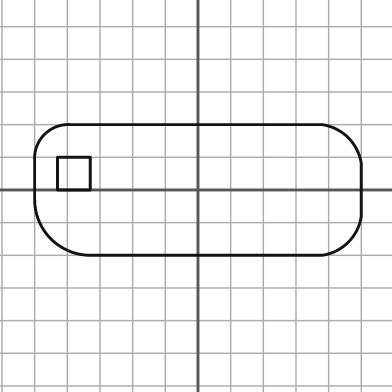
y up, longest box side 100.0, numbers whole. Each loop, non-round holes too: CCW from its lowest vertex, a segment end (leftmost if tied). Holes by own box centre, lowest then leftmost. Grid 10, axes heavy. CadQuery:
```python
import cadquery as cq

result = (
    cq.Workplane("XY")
    .moveTo(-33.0, -20.0)
    .lineTo(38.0, -20.0)
    .threePointArc((46.0, -16.0), (50.0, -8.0))
    .lineTo(50.0, 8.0)
    .threePointArc((46.0, 16.0), (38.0, 20.0))
    .lineTo(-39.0, 20.0)
    .threePointArc((-47.0, 17.0), (-50.0, 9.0))
    .lineTo(-50.0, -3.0)
    .threePointArc((-45.0, -15.0), (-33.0, -20.0))
    .close()
    .moveTo(-43.0, 0.0)
    .lineTo(-33.0, 0.0)
    .lineTo(-33.0, 10.0)
    .lineTo(-43.0, 10.0)
    .close()
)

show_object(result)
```